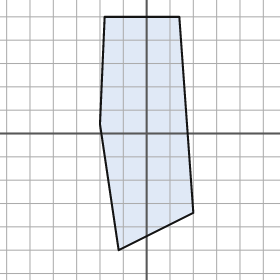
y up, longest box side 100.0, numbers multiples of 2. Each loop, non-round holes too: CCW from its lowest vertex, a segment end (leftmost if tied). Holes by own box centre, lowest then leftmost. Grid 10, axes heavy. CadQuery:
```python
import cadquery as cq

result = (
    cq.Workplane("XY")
    .moveTo(-12.0, -50.0)
    .lineTo(20.0, -34.0)
    .lineTo(14.0, 50.0)
    .lineTo(-18.0, 50.0)
    .lineTo(-20.0, 4.0)
    .close()
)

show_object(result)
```